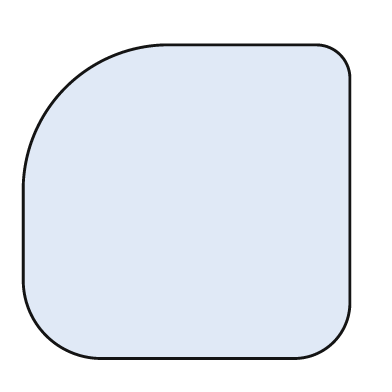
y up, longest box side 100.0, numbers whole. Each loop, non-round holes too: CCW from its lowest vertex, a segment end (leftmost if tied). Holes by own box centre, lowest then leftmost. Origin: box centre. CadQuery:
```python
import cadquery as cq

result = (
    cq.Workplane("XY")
    .moveTo(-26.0, -48.0)
    .lineTo(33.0, -48.0)
    .threePointArc((45.0, -43.0), (50.0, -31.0))
    .lineTo(50.0, 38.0)
    .threePointArc((47.0, 45.0), (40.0, 48.0))
    .lineTo(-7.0, 48.0)
    .threePointArc((-37.0, 35.0), (-50.0, 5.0))
    .lineTo(-50.0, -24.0)
    .threePointArc((-43.0, -41.0), (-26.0, -48.0))
    .close()
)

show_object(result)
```